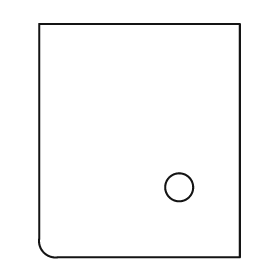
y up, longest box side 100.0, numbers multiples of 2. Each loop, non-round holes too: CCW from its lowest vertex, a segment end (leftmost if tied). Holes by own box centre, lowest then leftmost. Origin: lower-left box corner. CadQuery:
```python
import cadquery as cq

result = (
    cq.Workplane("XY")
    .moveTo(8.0, 0.0)
    .lineTo(86.0, 0.0)
    .lineTo(86.0, 100.0)
    .lineTo(0.0, 100.0)
    .lineTo(0.0, 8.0)
    .threePointArc((2.0, 2.0), (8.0, 0.0))
    .close()
    .moveTo(60.0, 30.0)
    .circle(6.0)
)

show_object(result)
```